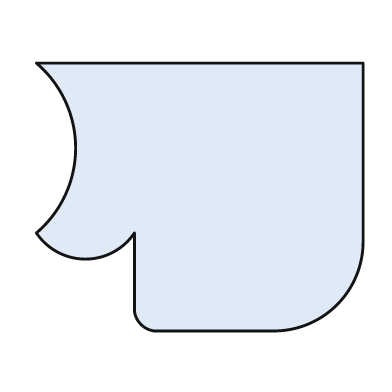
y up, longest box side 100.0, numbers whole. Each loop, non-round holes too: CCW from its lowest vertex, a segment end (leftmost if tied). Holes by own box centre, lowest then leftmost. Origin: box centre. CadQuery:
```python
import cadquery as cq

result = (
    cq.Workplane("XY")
    .moveTo(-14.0, -41.0)
    .lineTo(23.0, -41.0)
    .threePointArc((42.0, -33.0), (50.0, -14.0))
    .lineTo(50.0, 41.0)
    .lineTo(-50.0, 41.0)
    .threePointArc((-38.0, 15.0), (-50.0, -11.0))
    .threePointArc((-35.0, -19.0), (-20.0, -11.0))
    .lineTo(-20.0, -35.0)
    .threePointArc((-18.0, -39.0), (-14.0, -41.0))
    .close()
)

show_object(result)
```